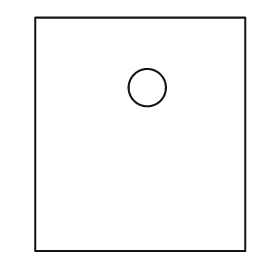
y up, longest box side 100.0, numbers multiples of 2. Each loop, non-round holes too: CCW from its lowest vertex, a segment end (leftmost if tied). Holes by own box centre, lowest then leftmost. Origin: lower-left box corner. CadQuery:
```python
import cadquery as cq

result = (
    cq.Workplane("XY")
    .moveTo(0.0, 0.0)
    .lineTo(90.0, 0.0)
    .lineTo(90.0, 100.0)
    .lineTo(0.0, 100.0)
    .close()
    .moveTo(48.0, 70.0)
    .circle(8.0)
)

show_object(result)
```